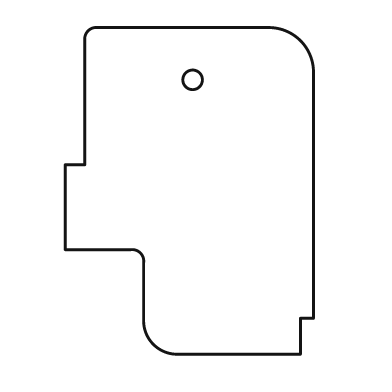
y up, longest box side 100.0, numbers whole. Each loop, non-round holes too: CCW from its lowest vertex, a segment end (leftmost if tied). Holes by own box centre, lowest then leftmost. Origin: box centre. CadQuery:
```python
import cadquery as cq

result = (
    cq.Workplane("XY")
    .moveTo(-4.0, -50.0)
    .lineTo(34.0, -50.0)
    .lineTo(34.0, -39.0)
    .lineTo(38.0, -39.0)
    .lineTo(38.0, 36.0)
    .threePointArc((34.0, 46.0), (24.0, 50.0))
    .lineTo(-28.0, 50.0)
    .threePointArc((-31.0, 49.0), (-32.0, 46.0))
    .lineTo(-32.0, 8.0)
    .lineTo(-38.0, 8.0)
    .lineTo(-38.0, -18.0)
    .lineTo(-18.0, -18.0)
    .threePointArc((-15.0, -19.0), (-14.0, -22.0))
    .lineTo(-14.0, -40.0)
    .threePointArc((-11.0, -47.0), (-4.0, -50.0))
    .close()
    .moveTo(1.0, 34.0)
    .circle(3.0)
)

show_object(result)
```